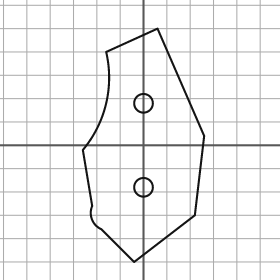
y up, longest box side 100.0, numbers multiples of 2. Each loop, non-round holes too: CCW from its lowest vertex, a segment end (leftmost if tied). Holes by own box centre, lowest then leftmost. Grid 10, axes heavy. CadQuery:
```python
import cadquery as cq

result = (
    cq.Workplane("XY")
    .moveTo(-4.0, -50.0)
    .lineTo(22.0, -30.0)
    .lineTo(26.0, 4.0)
    .lineTo(6.0, 50.0)
    .lineTo(-16.0, 40.0)
    .threePointArc((-16.0, 18.0), (-26.0, -2.0))
    .lineTo(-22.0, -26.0)
    .threePointArc((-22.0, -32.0), (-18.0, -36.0))
    .close()
    .moveTo(0.0, -18.0)
    .circle(4.0)
    .moveTo(0.0, 18.0)
    .circle(4.0)
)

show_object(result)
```